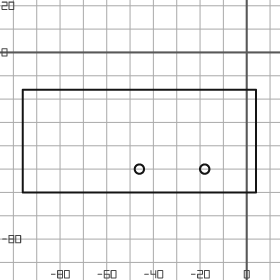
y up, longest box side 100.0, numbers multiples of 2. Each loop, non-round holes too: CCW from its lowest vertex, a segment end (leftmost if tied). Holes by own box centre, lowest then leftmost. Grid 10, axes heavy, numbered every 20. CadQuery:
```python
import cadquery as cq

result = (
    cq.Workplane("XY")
    .moveTo(-96.0, -60.0)
    .lineTo(4.0, -60.0)
    .lineTo(4.0, -16.0)
    .lineTo(-96.0, -16.0)
    .close()
    .moveTo(-46.0, -50.0)
    .circle(2.0)
    .moveTo(-18.0, -50.0)
    .circle(2.0)
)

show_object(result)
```